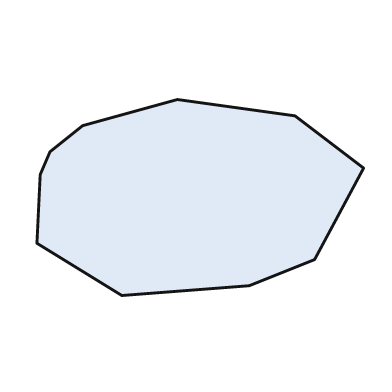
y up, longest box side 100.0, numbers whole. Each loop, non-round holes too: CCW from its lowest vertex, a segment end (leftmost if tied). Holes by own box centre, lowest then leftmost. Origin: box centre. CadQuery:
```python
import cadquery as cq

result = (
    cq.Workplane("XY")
    .moveTo(-24.0, -30.0)
    .lineTo(15.0, -27.0)
    .lineTo(35.0, -19.0)
    .lineTo(50.0, 9.0)
    .lineTo(29.0, 25.0)
    .lineTo(-7.0, 30.0)
    .lineTo(-36.0, 22.0)
    .lineTo(-46.0, 14.0)
    .lineTo(-49.0, 7.0)
    .lineTo(-50.0, -14.0)
    .close()
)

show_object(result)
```